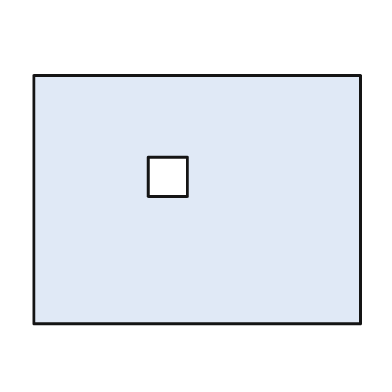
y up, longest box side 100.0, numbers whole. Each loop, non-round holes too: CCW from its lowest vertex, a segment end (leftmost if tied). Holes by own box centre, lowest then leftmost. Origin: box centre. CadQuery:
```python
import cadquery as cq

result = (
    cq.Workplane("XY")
    .moveTo(-50.0, -38.0)
    .lineTo(50.0, -38.0)
    .lineTo(50.0, 38.0)
    .lineTo(-50.0, 38.0)
    .close()
    .moveTo(-15.0, 1.0)
    .lineTo(-3.0, 1.0)
    .lineTo(-3.0, 13.0)
    .lineTo(-15.0, 13.0)
    .close()
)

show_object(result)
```